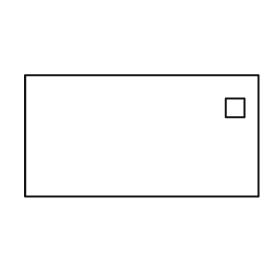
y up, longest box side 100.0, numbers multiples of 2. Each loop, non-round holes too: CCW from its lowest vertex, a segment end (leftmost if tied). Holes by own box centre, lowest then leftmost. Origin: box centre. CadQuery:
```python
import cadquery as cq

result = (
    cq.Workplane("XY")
    .moveTo(-50.0, -26.0)
    .lineTo(50.0, -26.0)
    .lineTo(50.0, 26.0)
    .lineTo(-50.0, 26.0)
    .close()
    .moveTo(36.0, 8.0)
    .lineTo(44.0, 8.0)
    .lineTo(44.0, 16.0)
    .lineTo(36.0, 16.0)
    .close()
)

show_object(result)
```